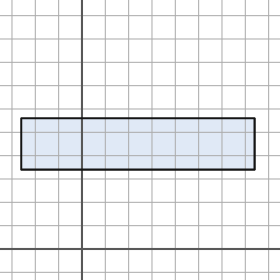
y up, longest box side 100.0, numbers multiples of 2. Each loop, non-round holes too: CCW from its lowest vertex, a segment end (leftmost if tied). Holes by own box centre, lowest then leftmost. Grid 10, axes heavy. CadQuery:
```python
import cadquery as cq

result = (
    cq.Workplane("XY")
    .moveTo(-26.0, 34.0)
    .lineTo(74.0, 34.0)
    .lineTo(74.0, 56.0)
    .lineTo(-26.0, 56.0)
    .close()
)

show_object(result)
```